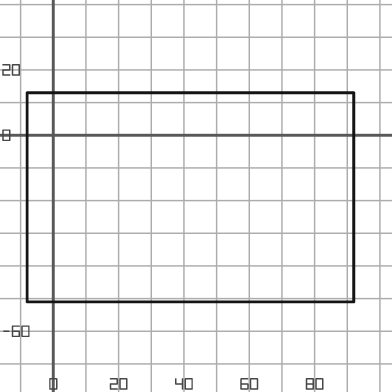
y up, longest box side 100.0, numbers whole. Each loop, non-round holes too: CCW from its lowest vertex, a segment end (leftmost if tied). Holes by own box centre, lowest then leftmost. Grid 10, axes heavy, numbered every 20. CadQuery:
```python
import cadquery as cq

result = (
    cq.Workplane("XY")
    .moveTo(-8.0, -51.0)
    .lineTo(92.0, -51.0)
    .lineTo(92.0, 13.0)
    .lineTo(-8.0, 13.0)
    .close()
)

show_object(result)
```